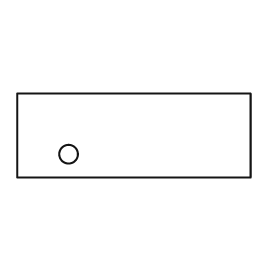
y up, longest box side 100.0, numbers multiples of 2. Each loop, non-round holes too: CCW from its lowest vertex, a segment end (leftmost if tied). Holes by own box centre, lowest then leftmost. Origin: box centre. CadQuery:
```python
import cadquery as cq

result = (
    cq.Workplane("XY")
    .moveTo(-50.0, -18.0)
    .lineTo(50.0, -18.0)
    .lineTo(50.0, 18.0)
    .lineTo(-50.0, 18.0)
    .close()
    .moveTo(-28.0, -8.0)
    .circle(4.0)
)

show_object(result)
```